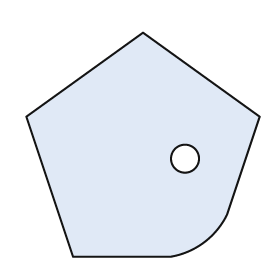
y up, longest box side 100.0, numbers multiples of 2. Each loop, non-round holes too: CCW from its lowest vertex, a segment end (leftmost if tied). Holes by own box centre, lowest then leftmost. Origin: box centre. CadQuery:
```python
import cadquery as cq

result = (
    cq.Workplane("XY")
    .moveTo(-30.0, -48.0)
    .lineTo(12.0, -48.0)
    .threePointArc((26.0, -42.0), (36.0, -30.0))
    .lineTo(50.0, 12.0)
    .lineTo(0.0, 48.0)
    .lineTo(-50.0, 12.0)
    .close()
    .moveTo(18.0, -6.0)
    .circle(6.0)
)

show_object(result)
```